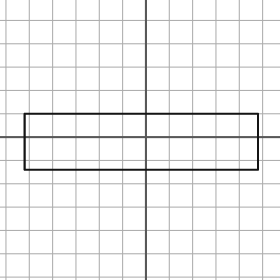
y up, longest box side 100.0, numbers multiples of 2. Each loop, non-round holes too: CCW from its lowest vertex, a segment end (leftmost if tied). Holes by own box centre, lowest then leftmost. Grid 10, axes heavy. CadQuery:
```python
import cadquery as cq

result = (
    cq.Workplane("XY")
    .moveTo(-52.0, -14.0)
    .lineTo(48.0, -14.0)
    .lineTo(48.0, 10.0)
    .lineTo(-52.0, 10.0)
    .close()
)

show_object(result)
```